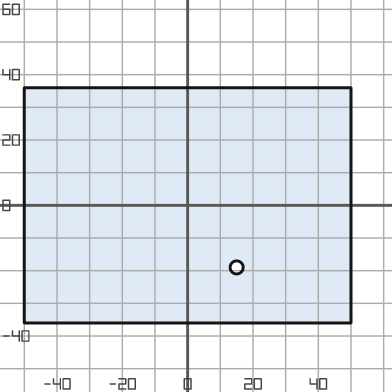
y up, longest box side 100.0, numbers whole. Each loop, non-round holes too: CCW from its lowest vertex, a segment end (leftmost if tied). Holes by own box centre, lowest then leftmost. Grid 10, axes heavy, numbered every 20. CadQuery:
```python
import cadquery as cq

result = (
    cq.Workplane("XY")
    .moveTo(-50.0, -36.0)
    .lineTo(50.0, -36.0)
    .lineTo(50.0, 36.0)
    .lineTo(-50.0, 36.0)
    .close()
    .moveTo(15.0, -19.0)
    .circle(2.0)
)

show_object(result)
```